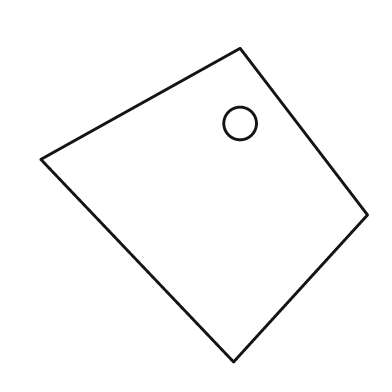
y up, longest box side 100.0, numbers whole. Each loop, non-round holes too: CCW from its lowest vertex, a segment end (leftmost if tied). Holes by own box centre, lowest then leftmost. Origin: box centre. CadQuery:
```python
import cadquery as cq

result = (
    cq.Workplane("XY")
    .moveTo(9.0, -48.0)
    .lineTo(50.0, -3.0)
    .lineTo(11.0, 48.0)
    .lineTo(-50.0, 14.0)
    .close()
    .moveTo(11.0, 25.0)
    .circle(5.0)
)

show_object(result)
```